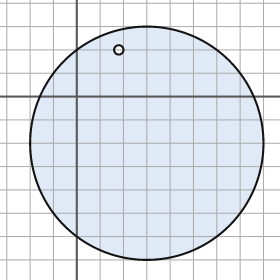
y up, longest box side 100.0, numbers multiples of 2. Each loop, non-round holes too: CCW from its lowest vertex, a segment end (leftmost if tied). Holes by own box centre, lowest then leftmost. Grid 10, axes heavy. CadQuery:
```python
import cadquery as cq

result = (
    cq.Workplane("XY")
    .moveTo(30.0, -20.0)
    .circle(50.0)
    .moveTo(18.0, 20.0)
    .circle(2.0)
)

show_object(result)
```